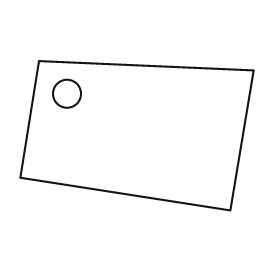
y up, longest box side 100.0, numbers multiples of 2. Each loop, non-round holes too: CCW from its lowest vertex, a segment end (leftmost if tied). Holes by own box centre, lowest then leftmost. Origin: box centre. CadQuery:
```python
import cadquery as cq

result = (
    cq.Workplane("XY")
    .moveTo(40.0, -32.0)
    .lineTo(50.0, 28.0)
    .lineTo(-42.0, 32.0)
    .lineTo(-50.0, -18.0)
    .close()
    .moveTo(-30.0, 18.0)
    .circle(6.0)
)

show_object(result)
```